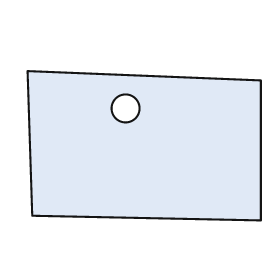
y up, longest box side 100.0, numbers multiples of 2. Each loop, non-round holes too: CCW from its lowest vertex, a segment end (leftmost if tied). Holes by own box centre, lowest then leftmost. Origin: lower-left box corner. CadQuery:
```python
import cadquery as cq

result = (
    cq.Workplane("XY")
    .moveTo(100.0, 0.0)
    .lineTo(100.0, 60.0)
    .lineTo(0.0, 64.0)
    .lineTo(2.0, 2.0)
    .close()
    .moveTo(42.0, 48.0)
    .circle(6.0)
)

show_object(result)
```